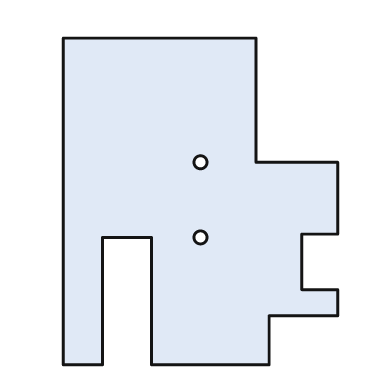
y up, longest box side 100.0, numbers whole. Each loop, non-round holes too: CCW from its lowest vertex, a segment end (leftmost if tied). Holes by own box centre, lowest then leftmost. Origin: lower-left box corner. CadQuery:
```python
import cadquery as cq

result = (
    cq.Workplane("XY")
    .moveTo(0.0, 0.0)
    .lineTo(12.0, 0.0)
    .lineTo(12.0, 39.0)
    .lineTo(27.0, 39.0)
    .lineTo(27.0, 0.0)
    .lineTo(63.0, 0.0)
    .lineTo(63.0, 15.0)
    .lineTo(84.0, 15.0)
    .lineTo(84.0, 23.0)
    .lineTo(73.0, 23.0)
    .lineTo(73.0, 40.0)
    .lineTo(84.0, 40.0)
    .lineTo(84.0, 62.0)
    .lineTo(59.0, 62.0)
    .lineTo(59.0, 100.0)
    .lineTo(0.0, 100.0)
    .close()
    .moveTo(42.0, 39.0)
    .circle(2.0)
    .moveTo(42.0, 62.0)
    .circle(2.0)
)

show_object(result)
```